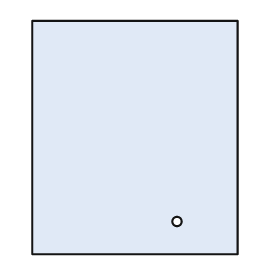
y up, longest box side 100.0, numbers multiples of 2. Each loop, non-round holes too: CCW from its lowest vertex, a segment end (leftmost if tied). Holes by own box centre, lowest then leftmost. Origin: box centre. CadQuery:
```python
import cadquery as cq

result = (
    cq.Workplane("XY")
    .moveTo(-44.0, -50.0)
    .lineTo(44.0, -50.0)
    .lineTo(44.0, 50.0)
    .lineTo(-44.0, 50.0)
    .close()
    .moveTo(18.0, -36.0)
    .circle(2.0)
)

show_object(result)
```